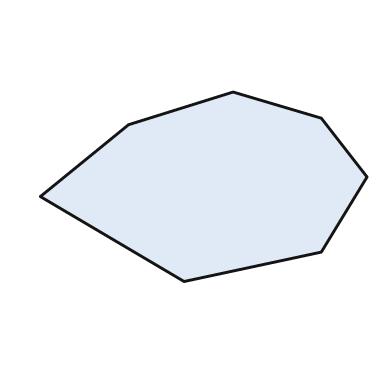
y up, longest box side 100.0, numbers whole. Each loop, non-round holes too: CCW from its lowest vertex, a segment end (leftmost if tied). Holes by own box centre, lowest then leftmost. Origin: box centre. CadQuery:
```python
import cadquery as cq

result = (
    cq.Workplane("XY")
    .moveTo(-6.0, -29.0)
    .lineTo(36.0, -20.0)
    .lineTo(50.0, 3.0)
    .lineTo(36.0, 21.0)
    .lineTo(9.0, 29.0)
    .lineTo(-23.0, 19.0)
    .lineTo(-50.0, -3.0)
    .close()
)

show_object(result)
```